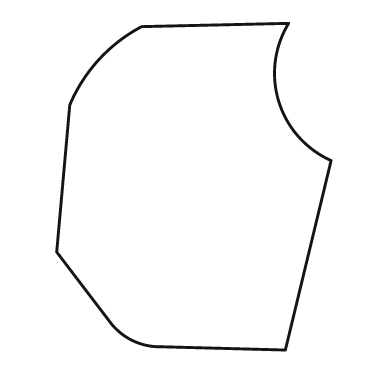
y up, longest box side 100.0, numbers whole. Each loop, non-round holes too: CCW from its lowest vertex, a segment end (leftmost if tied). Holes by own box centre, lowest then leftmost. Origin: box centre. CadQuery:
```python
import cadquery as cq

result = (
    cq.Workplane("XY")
    .moveTo(28.0, -50.0)
    .lineTo(42.0, 8.0)
    .threePointArc((26.0, 26.0), (29.0, 50.0))
    .lineTo(-16.0, 49.0)
    .threePointArc((-29.0, 39.0), (-38.0, 25.0))
    .lineTo(-42.0, -20.0)
    .lineTo(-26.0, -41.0)
    .threePointArc((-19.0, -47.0), (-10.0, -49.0))
    .close()
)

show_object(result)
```